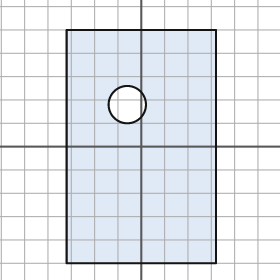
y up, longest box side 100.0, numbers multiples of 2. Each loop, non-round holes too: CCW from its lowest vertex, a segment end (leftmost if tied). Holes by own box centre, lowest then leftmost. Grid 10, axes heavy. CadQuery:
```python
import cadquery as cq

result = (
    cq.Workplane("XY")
    .moveTo(-32.0, -50.0)
    .lineTo(32.0, -50.0)
    .lineTo(32.0, 50.0)
    .lineTo(-32.0, 50.0)
    .close()
    .moveTo(-6.0, 18.0)
    .circle(8.0)
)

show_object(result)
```